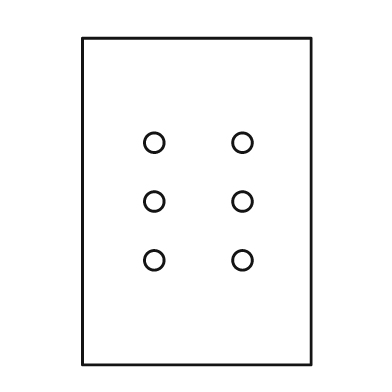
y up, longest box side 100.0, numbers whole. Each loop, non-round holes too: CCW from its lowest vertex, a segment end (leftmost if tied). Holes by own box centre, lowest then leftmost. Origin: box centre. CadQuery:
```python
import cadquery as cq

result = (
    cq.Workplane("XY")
    .moveTo(-35.0, -50.0)
    .lineTo(35.0, -50.0)
    .lineTo(35.0, 50.0)
    .lineTo(-35.0, 50.0)
    .close()
    .moveTo(-13.0, -18.0)
    .circle(3.0)
    .moveTo(14.0, -18.0)
    .circle(3.0)
    .moveTo(-13.0, 0.0)
    .circle(3.0)
    .moveTo(14.0, 0.0)
    .circle(3.0)
    .moveTo(-13.0, 18.0)
    .circle(3.0)
    .moveTo(14.0, 18.0)
    .circle(3.0)
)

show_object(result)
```